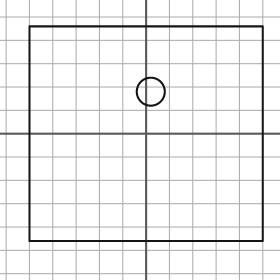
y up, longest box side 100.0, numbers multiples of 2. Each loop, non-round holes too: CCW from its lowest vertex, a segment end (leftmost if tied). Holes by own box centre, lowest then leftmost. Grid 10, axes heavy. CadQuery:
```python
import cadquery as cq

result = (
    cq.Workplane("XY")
    .moveTo(-50.0, -46.0)
    .lineTo(50.0, -46.0)
    .lineTo(50.0, 46.0)
    .lineTo(-50.0, 46.0)
    .close()
    .moveTo(2.0, 18.0)
    .circle(6.0)
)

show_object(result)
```